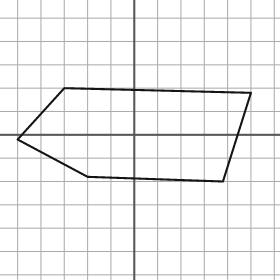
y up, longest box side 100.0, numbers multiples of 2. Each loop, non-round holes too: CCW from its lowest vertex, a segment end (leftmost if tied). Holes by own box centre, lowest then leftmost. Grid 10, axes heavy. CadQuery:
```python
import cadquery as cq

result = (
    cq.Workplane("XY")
    .moveTo(38.0, -20.0)
    .lineTo(50.0, 18.0)
    .lineTo(-30.0, 20.0)
    .lineTo(-50.0, -2.0)
    .lineTo(-20.0, -18.0)
    .close()
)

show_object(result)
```